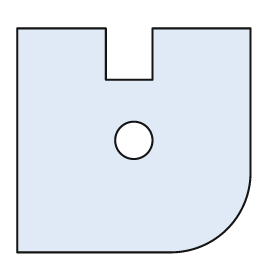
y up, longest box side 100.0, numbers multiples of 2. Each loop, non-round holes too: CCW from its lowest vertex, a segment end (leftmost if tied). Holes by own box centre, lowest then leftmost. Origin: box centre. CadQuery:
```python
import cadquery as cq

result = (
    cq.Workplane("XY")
    .moveTo(-50.0, -48.0)
    .lineTo(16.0, -48.0)
    .threePointArc((40.0, -38.0), (50.0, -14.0))
    .lineTo(50.0, 48.0)
    .lineTo(8.0, 48.0)
    .lineTo(8.0, 26.0)
    .lineTo(-12.0, 26.0)
    .lineTo(-12.0, 48.0)
    .lineTo(-50.0, 48.0)
    .close()
    .moveTo(0.0, 0.0)
    .circle(8.0)
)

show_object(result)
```